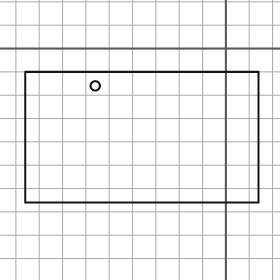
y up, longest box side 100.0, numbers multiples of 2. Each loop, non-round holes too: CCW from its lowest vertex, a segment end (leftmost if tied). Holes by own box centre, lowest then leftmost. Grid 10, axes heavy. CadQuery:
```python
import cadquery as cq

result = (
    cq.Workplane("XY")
    .moveTo(-86.0, -66.0)
    .lineTo(14.0, -66.0)
    .lineTo(14.0, -10.0)
    .lineTo(-86.0, -10.0)
    .close()
    .moveTo(-56.0, -16.0)
    .circle(2.0)
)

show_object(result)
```